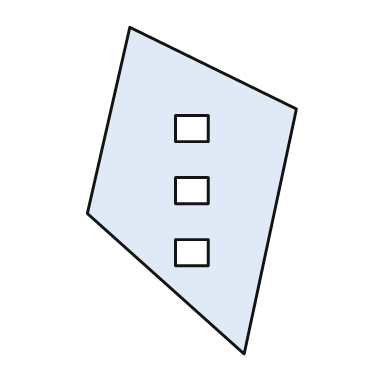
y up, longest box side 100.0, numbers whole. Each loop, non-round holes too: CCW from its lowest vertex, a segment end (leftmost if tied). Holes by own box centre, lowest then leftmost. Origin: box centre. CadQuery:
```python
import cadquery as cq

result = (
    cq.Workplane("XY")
    .moveTo(16.0, -50.0)
    .lineTo(32.0, 25.0)
    .lineTo(-19.0, 50.0)
    .lineTo(-32.0, -7.0)
    .close()
    .moveTo(-5.0, -23.0)
    .lineTo(5.0, -23.0)
    .lineTo(5.0, -15.0)
    .lineTo(-5.0, -15.0)
    .close()
    .moveTo(-5.0, -4.0)
    .lineTo(5.0, -4.0)
    .lineTo(5.0, 4.0)
    .lineTo(-5.0, 4.0)
    .close()
    .moveTo(-5.0, 15.0)
    .lineTo(5.0, 15.0)
    .lineTo(5.0, 23.0)
    .lineTo(-5.0, 23.0)
    .close()
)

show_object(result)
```